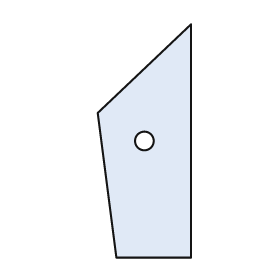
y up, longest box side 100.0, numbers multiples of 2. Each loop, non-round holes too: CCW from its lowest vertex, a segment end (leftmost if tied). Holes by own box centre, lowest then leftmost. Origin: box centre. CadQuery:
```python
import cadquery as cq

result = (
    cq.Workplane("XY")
    .moveTo(-12.0, -50.0)
    .lineTo(20.0, -50.0)
    .lineTo(20.0, 50.0)
    .lineTo(-20.0, 12.0)
    .close()
    .moveTo(0.0, 0.0)
    .circle(4.0)
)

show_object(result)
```